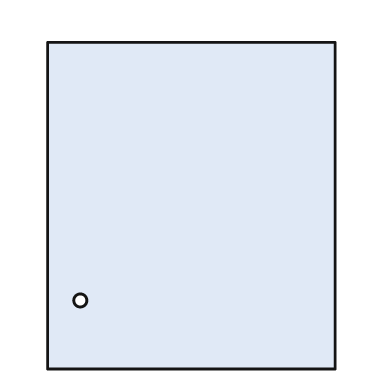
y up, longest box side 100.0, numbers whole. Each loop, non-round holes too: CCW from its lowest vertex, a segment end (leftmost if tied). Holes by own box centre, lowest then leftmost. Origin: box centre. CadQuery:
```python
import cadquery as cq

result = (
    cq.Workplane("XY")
    .moveTo(-44.0, -50.0)
    .lineTo(44.0, -50.0)
    .lineTo(44.0, 50.0)
    .lineTo(-44.0, 50.0)
    .close()
    .moveTo(-34.0, -29.0)
    .circle(2.0)
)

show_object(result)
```